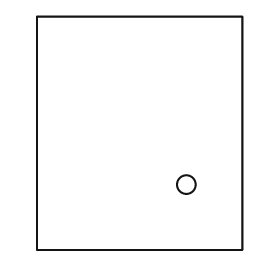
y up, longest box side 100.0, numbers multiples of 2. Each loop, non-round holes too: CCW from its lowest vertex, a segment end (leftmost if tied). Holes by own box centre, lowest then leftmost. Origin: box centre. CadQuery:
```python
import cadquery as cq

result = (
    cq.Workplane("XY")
    .moveTo(-44.0, -50.0)
    .lineTo(44.0, -50.0)
    .lineTo(44.0, 50.0)
    .lineTo(-44.0, 50.0)
    .close()
    .moveTo(20.0, -22.0)
    .circle(4.0)
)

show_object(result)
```